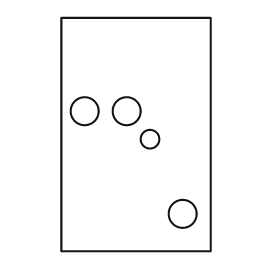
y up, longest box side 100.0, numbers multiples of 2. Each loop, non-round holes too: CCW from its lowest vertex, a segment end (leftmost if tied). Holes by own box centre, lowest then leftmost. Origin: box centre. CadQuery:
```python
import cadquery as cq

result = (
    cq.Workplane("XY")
    .moveTo(-32.0, -50.0)
    .lineTo(32.0, -50.0)
    .lineTo(32.0, 50.0)
    .lineTo(-32.0, 50.0)
    .close()
    .moveTo(20.0, -34.0)
    .circle(6.0)
    .moveTo(6.0, -2.0)
    .circle(4.0)
    .moveTo(-22.0, 10.0)
    .circle(6.0)
    .moveTo(-4.0, 10.0)
    .circle(6.0)
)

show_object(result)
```